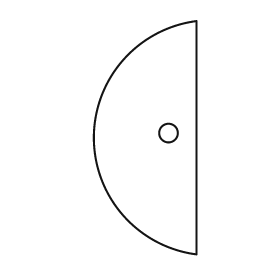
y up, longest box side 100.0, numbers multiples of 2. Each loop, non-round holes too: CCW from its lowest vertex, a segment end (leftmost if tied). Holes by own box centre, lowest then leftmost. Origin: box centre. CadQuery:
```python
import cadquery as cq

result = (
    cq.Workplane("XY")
    .moveTo(22.0, -50.0)
    .lineTo(22.0, 50.0)
    .threePointArc((-22.0, 0.0), (22.0, -50.0))
    .close()
    .moveTo(10.0, 2.0)
    .circle(4.0)
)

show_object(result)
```